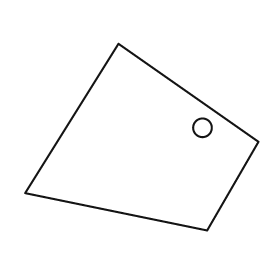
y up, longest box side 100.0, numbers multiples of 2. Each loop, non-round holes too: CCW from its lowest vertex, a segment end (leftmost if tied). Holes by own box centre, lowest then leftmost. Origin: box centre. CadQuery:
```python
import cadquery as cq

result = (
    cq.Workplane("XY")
    .moveTo(28.0, -40.0)
    .lineTo(50.0, -2.0)
    .lineTo(-10.0, 40.0)
    .lineTo(-50.0, -24.0)
    .close()
    .moveTo(26.0, 4.0)
    .circle(4.0)
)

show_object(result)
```